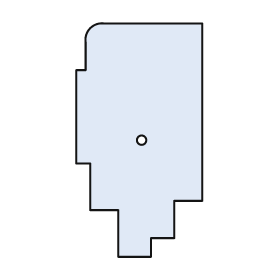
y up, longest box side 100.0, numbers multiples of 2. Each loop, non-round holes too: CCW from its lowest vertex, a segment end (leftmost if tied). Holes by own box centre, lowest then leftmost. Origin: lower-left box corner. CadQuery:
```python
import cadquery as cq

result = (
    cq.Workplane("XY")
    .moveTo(18.0, 0.0)
    .lineTo(32.0, 0.0)
    .lineTo(32.0, 8.0)
    .lineTo(42.0, 8.0)
    .lineTo(42.0, 24.0)
    .lineTo(54.0, 24.0)
    .lineTo(54.0, 100.0)
    .lineTo(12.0, 100.0)
    .threePointArc((6.0, 98.0), (4.0, 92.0))
    .lineTo(4.0, 80.0)
    .lineTo(0.0, 80.0)
    .lineTo(0.0, 40.0)
    .lineTo(6.0, 40.0)
    .lineTo(6.0, 20.0)
    .lineTo(18.0, 20.0)
    .close()
    .moveTo(28.0, 50.0)
    .circle(2.0)
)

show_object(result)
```